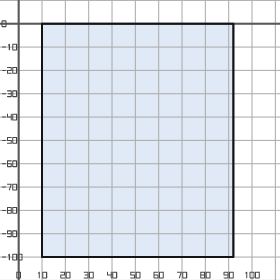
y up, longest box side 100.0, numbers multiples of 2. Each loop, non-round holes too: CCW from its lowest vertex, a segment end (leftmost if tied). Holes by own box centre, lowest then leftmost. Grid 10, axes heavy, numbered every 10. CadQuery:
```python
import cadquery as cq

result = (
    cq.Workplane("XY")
    .moveTo(10.0, -100.0)
    .lineTo(92.0, -100.0)
    .lineTo(92.0, 0.0)
    .lineTo(10.0, 0.0)
    .close()
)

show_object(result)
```